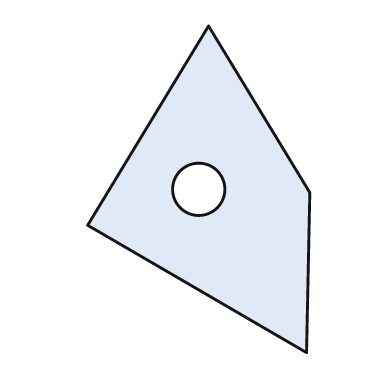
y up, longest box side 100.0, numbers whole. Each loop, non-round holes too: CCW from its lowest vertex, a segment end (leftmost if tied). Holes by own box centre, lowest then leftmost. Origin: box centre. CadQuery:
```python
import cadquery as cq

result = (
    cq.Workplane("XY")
    .moveTo(33.0, -50.0)
    .lineTo(34.0, -1.0)
    .lineTo(3.0, 50.0)
    .lineTo(-34.0, -11.0)
    .close()
    .moveTo(0.0, 0.0)
    .circle(8.0)
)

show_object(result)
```